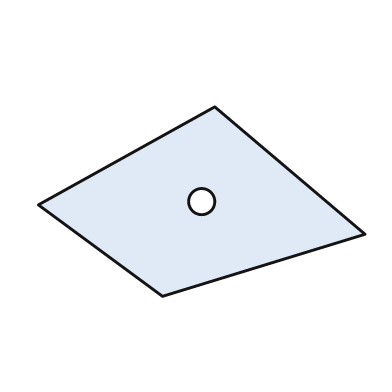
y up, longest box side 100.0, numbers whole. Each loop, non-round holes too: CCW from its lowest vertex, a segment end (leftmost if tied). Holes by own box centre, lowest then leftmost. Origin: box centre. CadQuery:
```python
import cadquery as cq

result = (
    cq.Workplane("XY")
    .moveTo(-12.0, -29.0)
    .lineTo(50.0, -10.0)
    .lineTo(4.0, 29.0)
    .lineTo(-50.0, -1.0)
    .close()
    .moveTo(0.0, 0.0)
    .circle(4.0)
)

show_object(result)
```